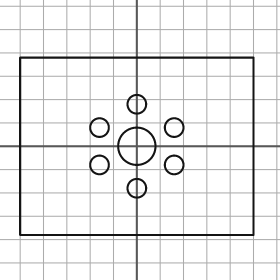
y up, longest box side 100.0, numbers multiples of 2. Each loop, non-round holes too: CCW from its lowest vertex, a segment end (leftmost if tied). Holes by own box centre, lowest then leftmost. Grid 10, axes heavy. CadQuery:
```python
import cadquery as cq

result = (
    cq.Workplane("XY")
    .moveTo(-50.0, -38.0)
    .lineTo(50.0, -38.0)
    .lineTo(50.0, 38.0)
    .lineTo(-50.0, 38.0)
    .close()
    .moveTo(0.0, -18.0)
    .circle(4.0)
    .moveTo(-16.0, -8.0)
    .circle(4.0)
    .moveTo(16.0, -8.0)
    .circle(4.0)
    .moveTo(0.0, 0.0)
    .circle(8.0)
    .moveTo(-16.0, 8.0)
    .circle(4.0)
    .moveTo(16.0, 8.0)
    .circle(4.0)
    .moveTo(0.0, 18.0)
    .circle(4.0)
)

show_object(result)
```